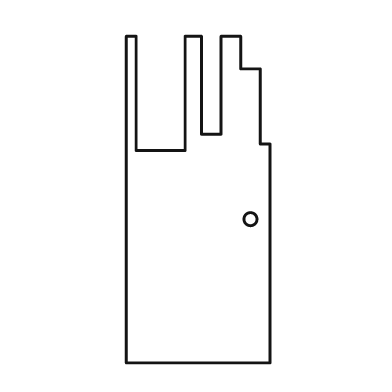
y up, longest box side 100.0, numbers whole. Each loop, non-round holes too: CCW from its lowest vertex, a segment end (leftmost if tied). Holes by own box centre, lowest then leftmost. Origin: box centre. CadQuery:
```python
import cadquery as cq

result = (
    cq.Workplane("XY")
    .moveTo(-22.0, -50.0)
    .lineTo(22.0, -50.0)
    .lineTo(22.0, 17.0)
    .lineTo(19.0, 17.0)
    .lineTo(19.0, 40.0)
    .lineTo(13.0, 40.0)
    .lineTo(13.0, 50.0)
    .lineTo(7.0, 50.0)
    .lineTo(7.0, 20.0)
    .lineTo(1.0, 20.0)
    .lineTo(1.0, 50.0)
    .lineTo(-4.0, 50.0)
    .lineTo(-4.0, 15.0)
    .lineTo(-19.0, 15.0)
    .lineTo(-19.0, 50.0)
    .lineTo(-22.0, 50.0)
    .close()
    .moveTo(16.0, -6.0)
    .circle(2.0)
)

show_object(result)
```